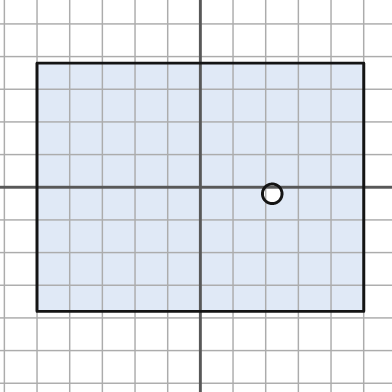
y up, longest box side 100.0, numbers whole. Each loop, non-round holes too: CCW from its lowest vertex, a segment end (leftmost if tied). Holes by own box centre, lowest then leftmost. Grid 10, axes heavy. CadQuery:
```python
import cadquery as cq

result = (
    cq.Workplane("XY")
    .moveTo(-50.0, -38.0)
    .lineTo(50.0, -38.0)
    .lineTo(50.0, 38.0)
    .lineTo(-50.0, 38.0)
    .close()
    .moveTo(22.0, -2.0)
    .circle(3.0)
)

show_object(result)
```